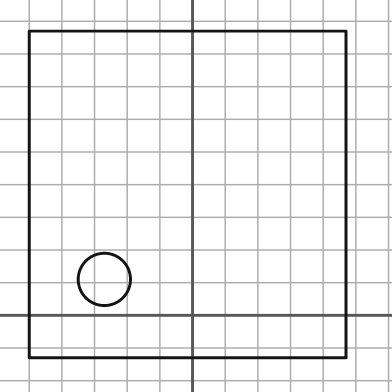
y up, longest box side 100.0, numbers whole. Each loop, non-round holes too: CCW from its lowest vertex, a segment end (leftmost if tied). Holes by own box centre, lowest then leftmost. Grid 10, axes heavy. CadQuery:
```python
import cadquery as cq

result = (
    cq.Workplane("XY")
    .moveTo(-50.0, -13.0)
    .lineTo(47.0, -13.0)
    .lineTo(47.0, 87.0)
    .lineTo(-50.0, 87.0)
    .close()
    .moveTo(-27.0, 11.0)
    .circle(8.0)
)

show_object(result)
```